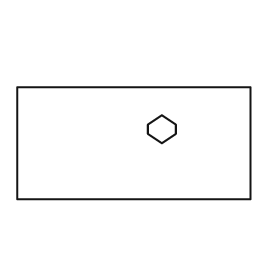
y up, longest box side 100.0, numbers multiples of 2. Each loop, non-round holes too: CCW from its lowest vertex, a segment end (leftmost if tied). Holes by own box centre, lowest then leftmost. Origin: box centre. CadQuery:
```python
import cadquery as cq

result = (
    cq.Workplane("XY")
    .moveTo(-50.0, -24.0)
    .lineTo(50.0, -24.0)
    .lineTo(50.0, 24.0)
    .lineTo(-50.0, 24.0)
    .close()
    .moveTo(12.0, 0.0)
    .lineTo(18.0, 4.0)
    .lineTo(18.0, 8.0)
    .lineTo(12.0, 12.0)
    .lineTo(6.0, 8.0)
    .lineTo(6.0, 4.0)
    .close()
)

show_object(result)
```